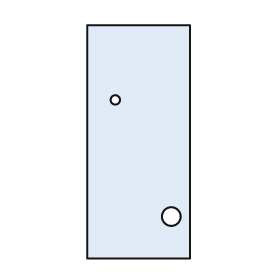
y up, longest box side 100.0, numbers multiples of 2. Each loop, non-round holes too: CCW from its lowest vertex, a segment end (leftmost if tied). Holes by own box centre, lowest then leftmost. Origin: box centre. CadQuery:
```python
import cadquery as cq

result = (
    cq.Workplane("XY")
    .moveTo(-22.0, -50.0)
    .lineTo(22.0, -50.0)
    .lineTo(22.0, 50.0)
    .lineTo(-22.0, 50.0)
    .close()
    .moveTo(14.0, -32.0)
    .circle(4.0)
    .moveTo(-10.0, 18.0)
    .circle(2.0)
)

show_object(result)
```